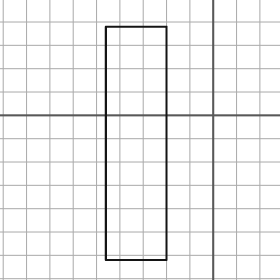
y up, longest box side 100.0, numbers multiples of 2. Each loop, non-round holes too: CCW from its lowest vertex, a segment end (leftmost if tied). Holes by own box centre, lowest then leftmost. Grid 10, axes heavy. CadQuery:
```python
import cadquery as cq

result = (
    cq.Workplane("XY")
    .moveTo(-46.0, -62.0)
    .lineTo(-20.0, -62.0)
    .lineTo(-20.0, 38.0)
    .lineTo(-46.0, 38.0)
    .close()
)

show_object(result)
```